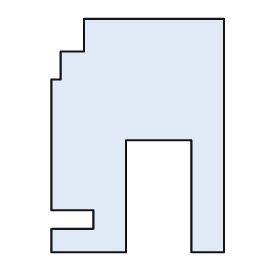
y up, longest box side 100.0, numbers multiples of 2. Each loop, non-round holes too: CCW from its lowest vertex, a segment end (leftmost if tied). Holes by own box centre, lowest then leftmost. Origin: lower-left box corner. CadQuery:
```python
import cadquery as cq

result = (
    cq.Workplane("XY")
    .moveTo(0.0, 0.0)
    .lineTo(32.0, 0.0)
    .lineTo(32.0, 48.0)
    .lineTo(60.0, 48.0)
    .lineTo(60.0, 0.0)
    .lineTo(74.0, 0.0)
    .lineTo(74.0, 100.0)
    .lineTo(14.0, 100.0)
    .lineTo(14.0, 86.0)
    .lineTo(4.0, 86.0)
    .lineTo(4.0, 74.0)
    .lineTo(0.0, 74.0)
    .lineTo(0.0, 18.0)
    .lineTo(18.0, 18.0)
    .lineTo(18.0, 10.0)
    .lineTo(0.0, 10.0)
    .close()
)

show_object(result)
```